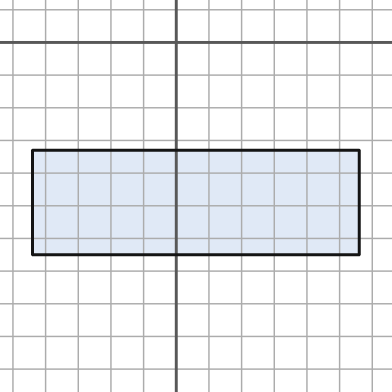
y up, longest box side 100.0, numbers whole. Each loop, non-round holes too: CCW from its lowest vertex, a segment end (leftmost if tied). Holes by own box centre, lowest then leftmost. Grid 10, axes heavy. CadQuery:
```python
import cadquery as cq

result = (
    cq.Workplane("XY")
    .moveTo(-44.0, -65.0)
    .lineTo(56.0, -65.0)
    .lineTo(56.0, -33.0)
    .lineTo(-44.0, -33.0)
    .close()
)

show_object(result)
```